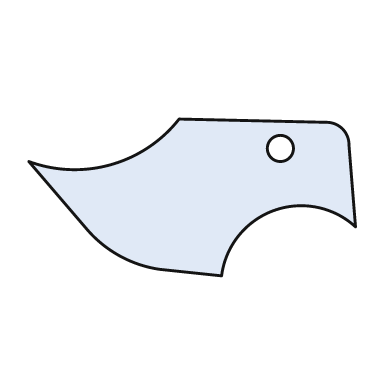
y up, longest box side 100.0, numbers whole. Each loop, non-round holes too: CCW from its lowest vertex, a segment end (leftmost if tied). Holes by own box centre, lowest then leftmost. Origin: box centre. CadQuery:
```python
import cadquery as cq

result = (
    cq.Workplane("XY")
    .moveTo(9.0, -24.0)
    .threePointArc((25.0, -4.0), (50.0, -9.0))
    .lineTo(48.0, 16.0)
    .threePointArc((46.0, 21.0), (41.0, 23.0))
    .lineTo(-4.0, 24.0)
    .threePointArc((-25.0, 10.0), (-50.0, 11.0))
    .lineTo(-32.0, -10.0)
    .threePointArc((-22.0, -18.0), (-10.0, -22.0))
    .close()
    .moveTo(27.0, 15.0)
    .circle(4.0)
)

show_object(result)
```